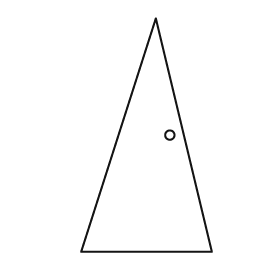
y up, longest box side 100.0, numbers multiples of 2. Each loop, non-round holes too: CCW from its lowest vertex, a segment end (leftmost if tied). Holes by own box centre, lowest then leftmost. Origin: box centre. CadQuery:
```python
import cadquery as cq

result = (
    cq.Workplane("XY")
    .moveTo(-28.0, -50.0)
    .lineTo(28.0, -50.0)
    .lineTo(4.0, 50.0)
    .close()
    .moveTo(10.0, 0.0)
    .circle(2.0)
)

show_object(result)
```